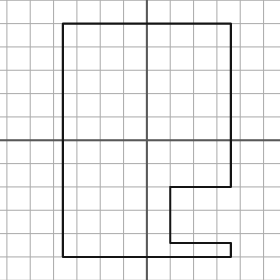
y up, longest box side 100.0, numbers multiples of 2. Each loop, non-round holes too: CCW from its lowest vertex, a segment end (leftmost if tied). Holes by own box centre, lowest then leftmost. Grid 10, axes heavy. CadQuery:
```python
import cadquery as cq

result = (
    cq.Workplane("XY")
    .moveTo(-36.0, -50.0)
    .lineTo(36.0, -50.0)
    .lineTo(36.0, -44.0)
    .lineTo(10.0, -44.0)
    .lineTo(10.0, -20.0)
    .lineTo(36.0, -20.0)
    .lineTo(36.0, 50.0)
    .lineTo(-36.0, 50.0)
    .close()
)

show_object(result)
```